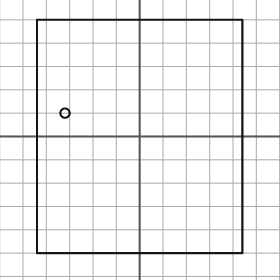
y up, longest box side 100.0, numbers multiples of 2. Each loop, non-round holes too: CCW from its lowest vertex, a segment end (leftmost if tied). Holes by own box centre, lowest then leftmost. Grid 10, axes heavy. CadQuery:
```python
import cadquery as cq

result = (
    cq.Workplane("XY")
    .moveTo(-44.0, -50.0)
    .lineTo(44.0, -50.0)
    .lineTo(44.0, 50.0)
    .lineTo(-44.0, 50.0)
    .close()
    .moveTo(-32.0, 10.0)
    .circle(2.0)
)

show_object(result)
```